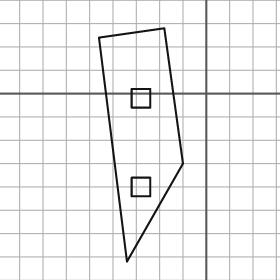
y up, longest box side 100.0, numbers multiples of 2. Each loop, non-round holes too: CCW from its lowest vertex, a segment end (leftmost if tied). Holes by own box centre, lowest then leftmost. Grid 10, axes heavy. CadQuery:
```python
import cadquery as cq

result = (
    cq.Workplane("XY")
    .moveTo(-34.0, -72.0)
    .lineTo(-10.0, -30.0)
    .lineTo(-18.0, 28.0)
    .lineTo(-46.0, 24.0)
    .close()
    .moveTo(-32.0, -44.0)
    .lineTo(-24.0, -44.0)
    .lineTo(-24.0, -36.0)
    .lineTo(-32.0, -36.0)
    .close()
    .moveTo(-32.0, -6.0)
    .lineTo(-24.0, -6.0)
    .lineTo(-24.0, 2.0)
    .lineTo(-32.0, 2.0)
    .close()
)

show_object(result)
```